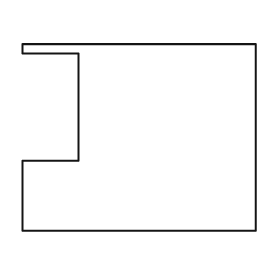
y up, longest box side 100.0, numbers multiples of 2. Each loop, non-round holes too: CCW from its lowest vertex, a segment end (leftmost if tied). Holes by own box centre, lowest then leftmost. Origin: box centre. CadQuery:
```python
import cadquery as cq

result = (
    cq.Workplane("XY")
    .moveTo(-50.0, -40.0)
    .lineTo(50.0, -40.0)
    .lineTo(50.0, 40.0)
    .lineTo(-50.0, 40.0)
    .lineTo(-50.0, 36.0)
    .lineTo(-26.0, 36.0)
    .lineTo(-26.0, -10.0)
    .lineTo(-50.0, -10.0)
    .close()
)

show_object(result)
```